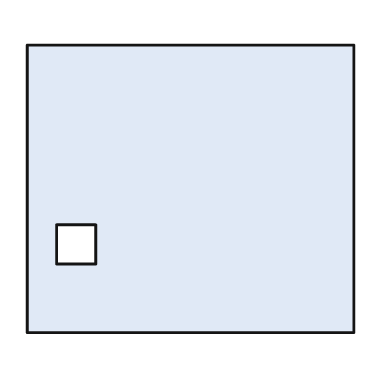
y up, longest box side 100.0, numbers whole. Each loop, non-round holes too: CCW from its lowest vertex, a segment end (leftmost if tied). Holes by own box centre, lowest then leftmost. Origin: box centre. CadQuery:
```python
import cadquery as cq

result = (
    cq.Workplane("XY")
    .moveTo(-50.0, -44.0)
    .lineTo(50.0, -44.0)
    .lineTo(50.0, 44.0)
    .lineTo(-50.0, 44.0)
    .close()
    .moveTo(-41.0, -23.0)
    .lineTo(-29.0, -23.0)
    .lineTo(-29.0, -11.0)
    .lineTo(-41.0, -11.0)
    .close()
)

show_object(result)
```